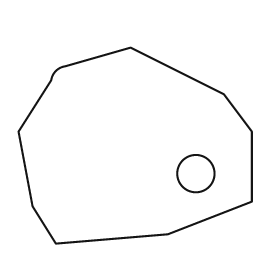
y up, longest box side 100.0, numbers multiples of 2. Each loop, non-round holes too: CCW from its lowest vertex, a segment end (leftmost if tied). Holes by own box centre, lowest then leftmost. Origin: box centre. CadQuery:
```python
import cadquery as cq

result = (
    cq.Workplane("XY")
    .moveTo(-34.0, -42.0)
    .lineTo(14.0, -38.0)
    .lineTo(50.0, -24.0)
    .lineTo(50.0, 6.0)
    .lineTo(38.0, 22.0)
    .lineTo(-2.0, 42.0)
    .lineTo(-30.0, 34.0)
    .threePointArc((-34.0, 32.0), (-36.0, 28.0))
    .lineTo(-50.0, 6.0)
    .lineTo(-44.0, -26.0)
    .close()
    .moveTo(26.0, -12.0)
    .circle(8.0)
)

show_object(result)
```